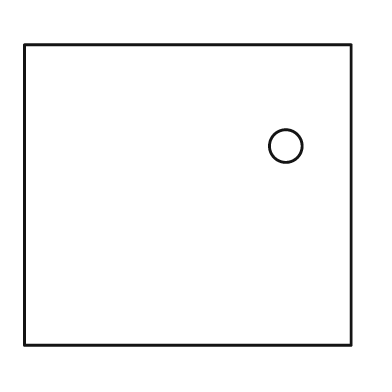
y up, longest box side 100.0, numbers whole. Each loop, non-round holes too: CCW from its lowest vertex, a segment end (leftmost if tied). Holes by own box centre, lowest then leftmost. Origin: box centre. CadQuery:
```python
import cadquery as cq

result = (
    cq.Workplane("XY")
    .moveTo(-50.0, -46.0)
    .lineTo(50.0, -46.0)
    .lineTo(50.0, 46.0)
    .lineTo(-50.0, 46.0)
    .close()
    .moveTo(30.0, 15.0)
    .circle(5.0)
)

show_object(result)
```